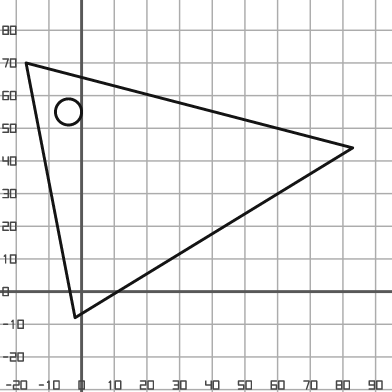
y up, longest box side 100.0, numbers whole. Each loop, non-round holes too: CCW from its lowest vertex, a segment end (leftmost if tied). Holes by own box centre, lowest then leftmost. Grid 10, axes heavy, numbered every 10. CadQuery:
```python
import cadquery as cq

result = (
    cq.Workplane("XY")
    .moveTo(-2.0, -8.0)
    .lineTo(83.0, 44.0)
    .lineTo(-17.0, 70.0)
    .close()
    .moveTo(-4.0, 55.0)
    .circle(4.0)
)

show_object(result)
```